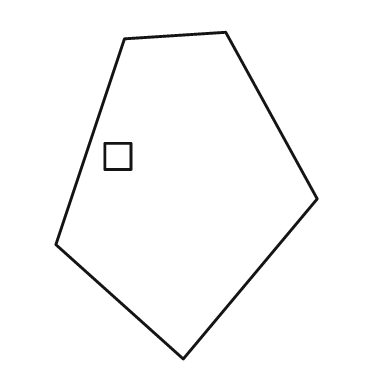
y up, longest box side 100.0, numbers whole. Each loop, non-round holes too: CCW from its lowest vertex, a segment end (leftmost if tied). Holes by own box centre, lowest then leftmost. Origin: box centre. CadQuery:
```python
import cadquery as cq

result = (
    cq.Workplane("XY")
    .moveTo(-1.0, -50.0)
    .lineTo(40.0, -1.0)
    .lineTo(12.0, 50.0)
    .lineTo(-19.0, 48.0)
    .lineTo(-40.0, -15.0)
    .close()
    .moveTo(-25.0, 8.0)
    .lineTo(-17.0, 8.0)
    .lineTo(-17.0, 16.0)
    .lineTo(-25.0, 16.0)
    .close()
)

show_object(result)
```